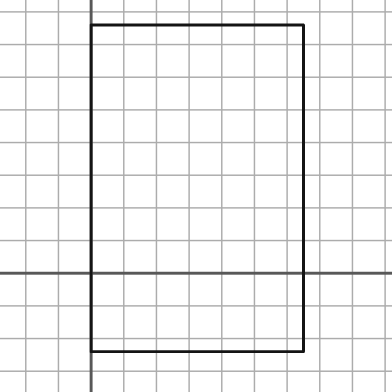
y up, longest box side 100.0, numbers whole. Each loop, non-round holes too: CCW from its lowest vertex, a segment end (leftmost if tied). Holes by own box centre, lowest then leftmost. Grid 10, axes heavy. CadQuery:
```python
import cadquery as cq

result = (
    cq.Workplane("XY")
    .moveTo(0.0, -24.0)
    .lineTo(65.0, -24.0)
    .lineTo(65.0, 76.0)
    .lineTo(0.0, 76.0)
    .close()
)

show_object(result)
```